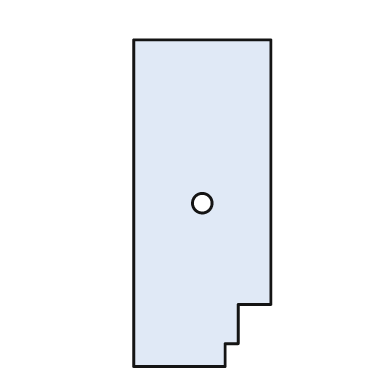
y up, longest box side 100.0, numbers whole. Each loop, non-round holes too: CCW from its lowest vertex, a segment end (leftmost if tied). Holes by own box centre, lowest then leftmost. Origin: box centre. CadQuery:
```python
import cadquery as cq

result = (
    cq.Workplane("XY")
    .moveTo(-21.0, -50.0)
    .lineTo(7.0, -50.0)
    .lineTo(7.0, -43.0)
    .lineTo(11.0, -43.0)
    .lineTo(11.0, -31.0)
    .lineTo(21.0, -31.0)
    .lineTo(21.0, 50.0)
    .lineTo(-21.0, 50.0)
    .close()
    .moveTo(0.0, 0.0)
    .circle(3.0)
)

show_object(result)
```